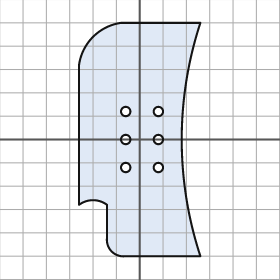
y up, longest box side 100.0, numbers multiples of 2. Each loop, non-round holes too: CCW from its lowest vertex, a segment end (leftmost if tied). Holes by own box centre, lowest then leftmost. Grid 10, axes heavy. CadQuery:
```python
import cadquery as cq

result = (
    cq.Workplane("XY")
    .moveTo(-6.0, -50.0)
    .lineTo(26.0, -50.0)
    .threePointArc((18.0, 0.0), (26.0, 50.0))
    .lineTo(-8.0, 50.0)
    .threePointArc((-20.0, 44.0), (-26.0, 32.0))
    .lineTo(-26.0, -28.0)
    .threePointArc((-20.0, -26.0), (-14.0, -28.0))
    .lineTo(-14.0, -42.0)
    .threePointArc((-12.0, -48.0), (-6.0, -50.0))
    .close()
    .moveTo(-6.0, -12.0)
    .circle(2.0)
    .moveTo(8.0, -12.0)
    .circle(2.0)
    .moveTo(-6.0, 0.0)
    .circle(2.0)
    .moveTo(8.0, 0.0)
    .circle(2.0)
    .moveTo(-6.0, 12.0)
    .circle(2.0)
    .moveTo(8.0, 12.0)
    .circle(2.0)
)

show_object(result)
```